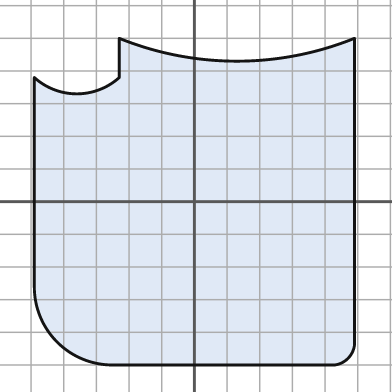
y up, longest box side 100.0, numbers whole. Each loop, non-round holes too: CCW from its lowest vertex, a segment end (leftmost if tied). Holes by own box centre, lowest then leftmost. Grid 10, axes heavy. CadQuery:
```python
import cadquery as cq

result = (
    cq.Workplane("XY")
    .moveTo(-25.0, -50.0)
    .lineTo(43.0, -50.0)
    .threePointArc((47.0, -48.0), (49.0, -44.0))
    .lineTo(49.0, 50.0)
    .threePointArc((13.0, 43.0), (-23.0, 50.0))
    .lineTo(-23.0, 38.0)
    .threePointArc((-36.0, 33.0), (-49.0, 38.0))
    .lineTo(-49.0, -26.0)
    .threePointArc((-42.0, -43.0), (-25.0, -50.0))
    .close()
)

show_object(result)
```